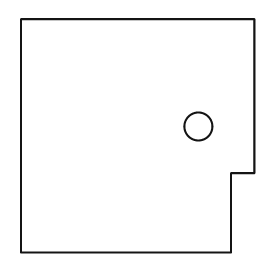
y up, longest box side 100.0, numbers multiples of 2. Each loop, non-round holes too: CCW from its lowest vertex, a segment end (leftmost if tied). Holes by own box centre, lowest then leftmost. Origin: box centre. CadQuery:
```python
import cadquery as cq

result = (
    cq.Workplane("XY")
    .moveTo(-50.0, -50.0)
    .lineTo(40.0, -50.0)
    .lineTo(40.0, -16.0)
    .lineTo(50.0, -16.0)
    .lineTo(50.0, 50.0)
    .lineTo(-50.0, 50.0)
    .close()
    .moveTo(26.0, 4.0)
    .circle(6.0)
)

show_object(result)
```